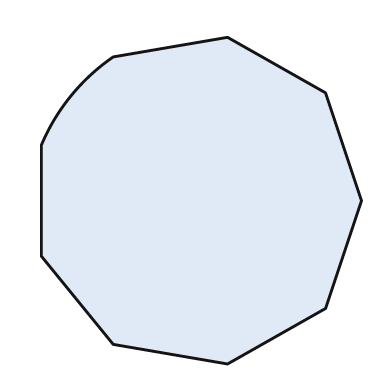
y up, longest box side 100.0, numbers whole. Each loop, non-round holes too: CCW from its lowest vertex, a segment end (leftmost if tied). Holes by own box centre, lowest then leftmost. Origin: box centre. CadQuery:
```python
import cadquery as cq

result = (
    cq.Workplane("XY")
    .moveTo(8.0, -50.0)
    .lineTo(38.0, -33.0)
    .lineTo(49.0, 0.0)
    .lineTo(38.0, 33.0)
    .lineTo(8.0, 50.0)
    .lineTo(-27.0, 44.0)
    .threePointArc((-40.0, 32.0), (-49.0, 17.0))
    .lineTo(-49.0, -17.0)
    .lineTo(-27.0, -44.0)
    .close()
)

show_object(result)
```